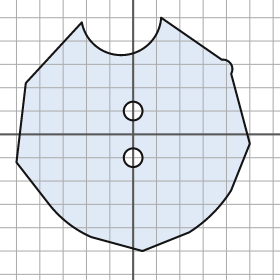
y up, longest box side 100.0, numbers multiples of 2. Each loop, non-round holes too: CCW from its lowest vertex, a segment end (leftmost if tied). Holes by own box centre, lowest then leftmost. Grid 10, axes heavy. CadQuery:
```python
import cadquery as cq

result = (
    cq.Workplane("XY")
    .moveTo(4.0, -50.0)
    .lineTo(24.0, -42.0)
    .threePointArc((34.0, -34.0), (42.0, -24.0))
    .lineTo(50.0, -4.0)
    .lineTo(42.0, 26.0)
    .threePointArc((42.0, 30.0), (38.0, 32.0))
    .lineTo(12.0, 50.0)
    .threePointArc((-4.0, 34.0), (-22.0, 48.0))
    .lineTo(-46.0, 22.0)
    .lineTo(-50.0, -12.0)
    .lineTo(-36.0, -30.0)
    .threePointArc((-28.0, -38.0), (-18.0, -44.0))
    .close()
    .moveTo(0.0, -10.0)
    .circle(4.0)
    .moveTo(0.0, 10.0)
    .circle(4.0)
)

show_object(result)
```